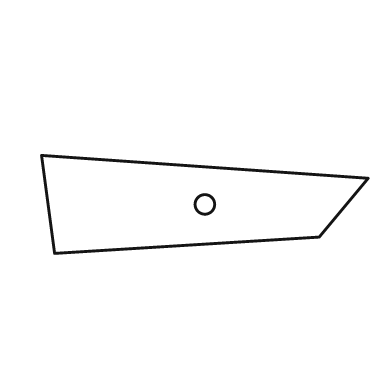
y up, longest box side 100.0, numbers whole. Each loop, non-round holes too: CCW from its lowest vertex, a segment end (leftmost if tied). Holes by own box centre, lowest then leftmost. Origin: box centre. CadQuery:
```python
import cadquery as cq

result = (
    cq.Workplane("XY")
    .moveTo(-46.0, -15.0)
    .lineTo(35.0, -10.0)
    .lineTo(50.0, 8.0)
    .lineTo(-50.0, 15.0)
    .close()
    .moveTo(0.0, 0.0)
    .circle(3.0)
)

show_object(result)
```